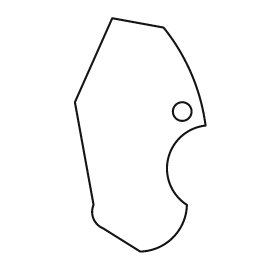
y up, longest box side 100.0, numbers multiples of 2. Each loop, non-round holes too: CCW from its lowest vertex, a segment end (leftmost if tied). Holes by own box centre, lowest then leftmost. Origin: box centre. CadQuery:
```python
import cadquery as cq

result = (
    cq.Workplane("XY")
    .moveTo(0.0, -50.0)
    .threePointArc((14.0, -44.0), (20.0, -30.0))
    .threePointArc((12.0, -10.0), (28.0, 4.0))
    .threePointArc((22.0, 26.0), (10.0, 46.0))
    .lineTo(-12.0, 50.0)
    .lineTo(-28.0, 14.0)
    .lineTo(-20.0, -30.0)
    .threePointArc((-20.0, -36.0), (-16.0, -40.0))
    .close()
    .moveTo(18.0, 10.0)
    .circle(4.0)
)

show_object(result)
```